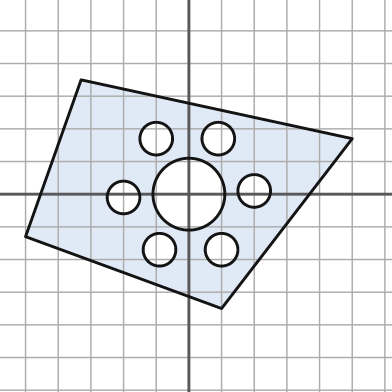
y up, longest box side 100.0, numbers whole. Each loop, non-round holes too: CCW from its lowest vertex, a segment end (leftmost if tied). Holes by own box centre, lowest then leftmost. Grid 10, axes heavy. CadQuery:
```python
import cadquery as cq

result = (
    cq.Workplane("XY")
    .moveTo(10.0, -35.0)
    .lineTo(50.0, 17.0)
    .lineTo(-33.0, 35.0)
    .lineTo(-50.0, -13.0)
    .close()
    .moveTo(-9.0, -17.0)
    .circle(5.0)
    .moveTo(10.0, -17.0)
    .circle(5.0)
    .moveTo(-20.0, -1.0)
    .circle(5.0)
    .moveTo(0.0, 0.0)
    .circle(11.0)
    .moveTo(20.0, 1.0)
    .circle(5.0)
    .moveTo(-10.0, 17.0)
    .circle(5.0)
    .moveTo(9.0, 17.0)
    .circle(5.0)
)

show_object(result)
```